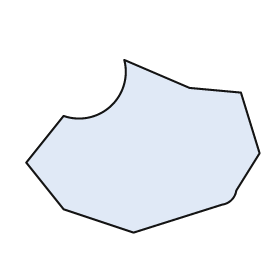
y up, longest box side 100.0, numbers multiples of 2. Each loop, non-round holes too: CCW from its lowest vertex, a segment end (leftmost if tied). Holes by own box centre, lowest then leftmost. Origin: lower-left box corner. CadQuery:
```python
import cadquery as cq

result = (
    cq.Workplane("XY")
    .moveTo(46.0, 0.0)
    .lineTo(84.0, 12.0)
    .threePointArc((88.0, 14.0), (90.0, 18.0))
    .lineTo(100.0, 34.0)
    .lineTo(92.0, 60.0)
    .lineTo(70.0, 62.0)
    .lineTo(42.0, 74.0)
    .threePointArc((36.0, 54.0), (16.0, 50.0))
    .lineTo(0.0, 30.0)
    .lineTo(16.0, 10.0)
    .close()
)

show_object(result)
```